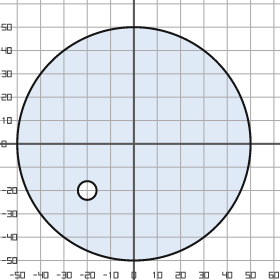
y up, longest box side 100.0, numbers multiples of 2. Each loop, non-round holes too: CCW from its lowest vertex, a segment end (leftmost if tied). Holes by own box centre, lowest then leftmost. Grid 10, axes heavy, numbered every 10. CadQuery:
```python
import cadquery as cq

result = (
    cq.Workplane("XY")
    .moveTo(0.0, 0.0)
    .circle(50.0)
    .moveTo(-20.0, -20.0)
    .circle(4.0)
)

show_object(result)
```